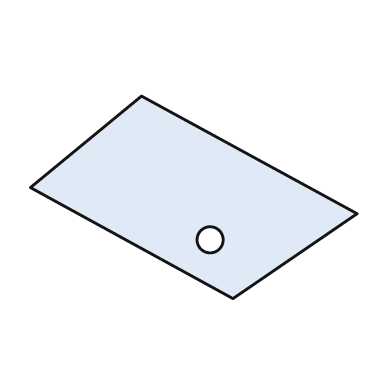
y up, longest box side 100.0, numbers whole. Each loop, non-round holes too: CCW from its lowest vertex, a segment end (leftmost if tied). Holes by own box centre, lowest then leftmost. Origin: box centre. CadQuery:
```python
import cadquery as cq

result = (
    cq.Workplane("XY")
    .moveTo(12.0, -31.0)
    .lineTo(50.0, -5.0)
    .lineTo(-16.0, 31.0)
    .lineTo(-50.0, 3.0)
    .close()
    .moveTo(5.0, -13.0)
    .circle(4.0)
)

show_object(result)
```